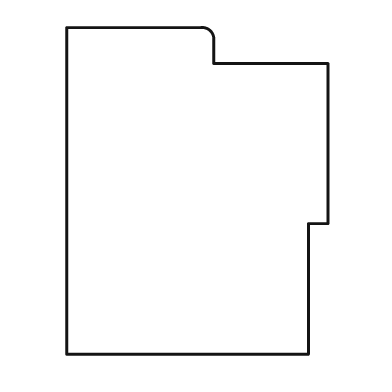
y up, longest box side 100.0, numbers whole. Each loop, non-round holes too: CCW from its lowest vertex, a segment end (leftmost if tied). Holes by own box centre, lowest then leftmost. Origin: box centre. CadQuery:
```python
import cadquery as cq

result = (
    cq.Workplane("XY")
    .moveTo(-40.0, -50.0)
    .lineTo(34.0, -50.0)
    .lineTo(34.0, -10.0)
    .lineTo(40.0, -10.0)
    .lineTo(40.0, 39.0)
    .lineTo(5.0, 39.0)
    .lineTo(5.0, 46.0)
    .threePointArc((4.0, 49.0), (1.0, 50.0))
    .lineTo(-40.0, 50.0)
    .close()
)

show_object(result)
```